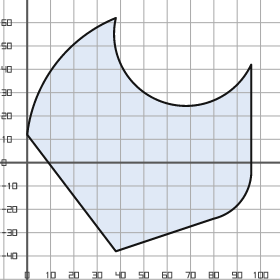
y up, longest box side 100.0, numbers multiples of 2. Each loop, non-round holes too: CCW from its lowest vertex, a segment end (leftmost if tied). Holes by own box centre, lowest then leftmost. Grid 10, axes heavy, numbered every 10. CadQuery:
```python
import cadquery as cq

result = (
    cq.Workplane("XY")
    .moveTo(38.0, -38.0)
    .lineTo(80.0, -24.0)
    .threePointArc((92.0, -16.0), (96.0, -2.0))
    .lineTo(96.0, 42.0)
    .threePointArc((58.0, 26.0), (38.0, 62.0))
    .threePointArc((12.0, 42.0), (0.0, 12.0))
    .close()
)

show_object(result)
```